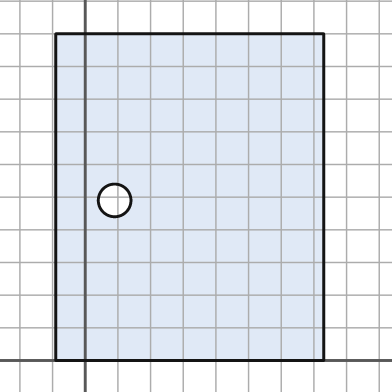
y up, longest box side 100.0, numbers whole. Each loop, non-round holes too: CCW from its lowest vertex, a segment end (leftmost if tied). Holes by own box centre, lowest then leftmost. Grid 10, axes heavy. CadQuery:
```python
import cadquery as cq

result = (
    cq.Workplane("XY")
    .moveTo(-9.0, 0.0)
    .lineTo(73.0, 0.0)
    .lineTo(73.0, 100.0)
    .lineTo(-9.0, 100.0)
    .close()
    .moveTo(9.0, 49.0)
    .circle(5.0)
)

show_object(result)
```